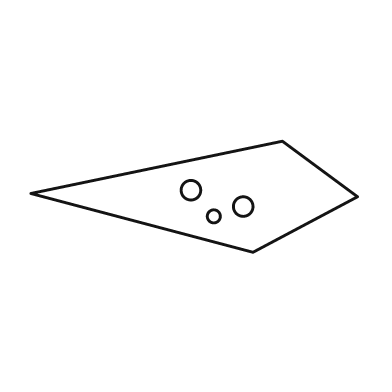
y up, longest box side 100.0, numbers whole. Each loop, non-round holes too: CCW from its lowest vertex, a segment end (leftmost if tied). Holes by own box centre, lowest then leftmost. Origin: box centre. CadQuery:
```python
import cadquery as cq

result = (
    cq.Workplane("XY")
    .moveTo(18.0, -17.0)
    .lineTo(50.0, 0.0)
    .lineTo(27.0, 17.0)
    .lineTo(-50.0, 1.0)
    .close()
    .moveTo(6.0, -6.0)
    .circle(2.0)
    .moveTo(15.0, -3.0)
    .circle(3.0)
    .moveTo(-1.0, 2.0)
    .circle(3.0)
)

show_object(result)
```